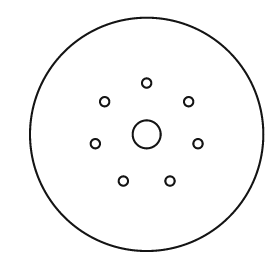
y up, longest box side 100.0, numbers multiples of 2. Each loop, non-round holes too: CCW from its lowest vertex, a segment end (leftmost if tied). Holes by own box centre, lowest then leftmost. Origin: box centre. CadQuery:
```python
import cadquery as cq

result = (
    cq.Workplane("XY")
    .moveTo(0.0, 0.0)
    .circle(50.0)
    .moveTo(-10.0, -20.0)
    .circle(2.0)
    .moveTo(10.0, -20.0)
    .circle(2.0)
    .moveTo(-22.0, -4.0)
    .circle(2.0)
    .moveTo(22.0, -4.0)
    .circle(2.0)
    .moveTo(0.0, 0.0)
    .circle(6.0)
    .moveTo(-18.0, 14.0)
    .circle(2.0)
    .moveTo(18.0, 14.0)
    .circle(2.0)
    .moveTo(0.0, 22.0)
    .circle(2.0)
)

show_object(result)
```